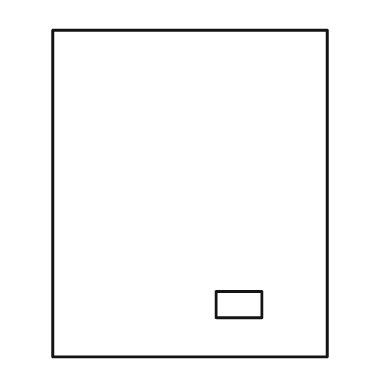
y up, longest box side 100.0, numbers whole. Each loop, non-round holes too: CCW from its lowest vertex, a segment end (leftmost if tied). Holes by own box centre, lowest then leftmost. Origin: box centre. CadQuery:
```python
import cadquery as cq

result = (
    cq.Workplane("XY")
    .moveTo(-42.0, -50.0)
    .lineTo(42.0, -50.0)
    .lineTo(42.0, 50.0)
    .lineTo(-42.0, 50.0)
    .close()
    .moveTo(8.0, -38.0)
    .lineTo(22.0, -38.0)
    .lineTo(22.0, -30.0)
    .lineTo(8.0, -30.0)
    .close()
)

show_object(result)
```